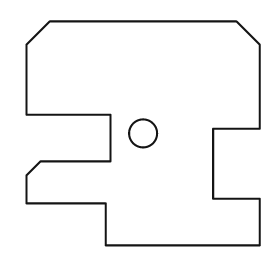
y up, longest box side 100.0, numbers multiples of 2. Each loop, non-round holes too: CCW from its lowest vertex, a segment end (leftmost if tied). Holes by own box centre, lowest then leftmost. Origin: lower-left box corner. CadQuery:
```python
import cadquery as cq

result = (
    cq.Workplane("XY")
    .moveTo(34.0, 0.0)
    .lineTo(100.0, 0.0)
    .lineTo(100.0, 20.0)
    .lineTo(80.0, 20.0)
    .lineTo(80.0, 50.0)
    .lineTo(100.0, 50.0)
    .lineTo(100.0, 86.0)
    .lineTo(90.0, 96.0)
    .lineTo(10.0, 96.0)
    .lineTo(0.0, 86.0)
    .lineTo(0.0, 56.0)
    .lineTo(36.0, 56.0)
    .lineTo(36.0, 36.0)
    .lineTo(6.0, 36.0)
    .lineTo(0.0, 30.0)
    .lineTo(0.0, 18.0)
    .lineTo(34.0, 18.0)
    .close()
    .moveTo(50.0, 48.0)
    .circle(6.0)
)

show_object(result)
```